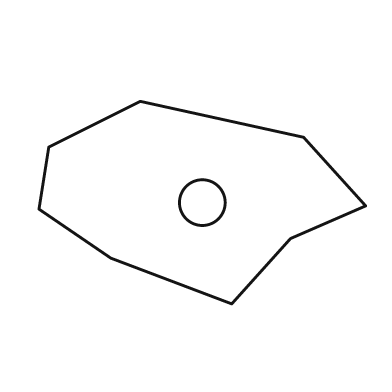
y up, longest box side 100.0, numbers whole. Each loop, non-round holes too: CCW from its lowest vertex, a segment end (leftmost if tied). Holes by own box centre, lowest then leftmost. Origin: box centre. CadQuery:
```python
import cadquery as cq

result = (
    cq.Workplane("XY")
    .moveTo(9.0, -31.0)
    .lineTo(27.0, -11.0)
    .lineTo(50.0, -1.0)
    .lineTo(31.0, 20.0)
    .lineTo(-19.0, 31.0)
    .lineTo(-47.0, 17.0)
    .lineTo(-50.0, -2.0)
    .lineTo(-28.0, -17.0)
    .close()
    .moveTo(0.0, 0.0)
    .circle(7.0)
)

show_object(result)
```